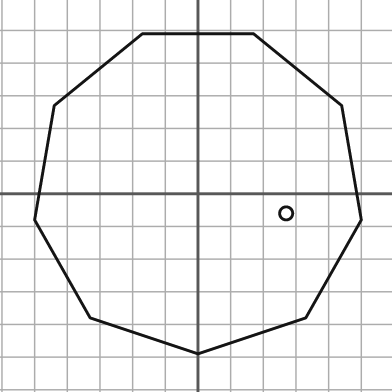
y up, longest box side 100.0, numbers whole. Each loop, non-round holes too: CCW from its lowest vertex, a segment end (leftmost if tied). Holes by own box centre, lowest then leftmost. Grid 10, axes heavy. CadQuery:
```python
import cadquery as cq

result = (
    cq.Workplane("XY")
    .moveTo(0.0, -49.0)
    .lineTo(33.0, -38.0)
    .lineTo(50.0, -8.0)
    .lineTo(44.0, 27.0)
    .lineTo(17.0, 49.0)
    .lineTo(-17.0, 49.0)
    .lineTo(-44.0, 27.0)
    .lineTo(-50.0, -8.0)
    .lineTo(-33.0, -38.0)
    .close()
    .moveTo(27.0, -6.0)
    .circle(2.0)
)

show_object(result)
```